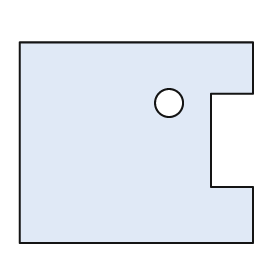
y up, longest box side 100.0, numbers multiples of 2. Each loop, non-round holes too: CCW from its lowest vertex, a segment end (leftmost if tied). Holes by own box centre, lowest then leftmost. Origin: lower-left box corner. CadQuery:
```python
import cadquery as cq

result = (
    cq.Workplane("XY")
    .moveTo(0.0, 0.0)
    .lineTo(100.0, 0.0)
    .lineTo(100.0, 24.0)
    .lineTo(82.0, 24.0)
    .lineTo(82.0, 64.0)
    .lineTo(100.0, 64.0)
    .lineTo(100.0, 86.0)
    .lineTo(0.0, 86.0)
    .close()
    .moveTo(64.0, 60.0)
    .circle(6.0)
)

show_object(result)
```